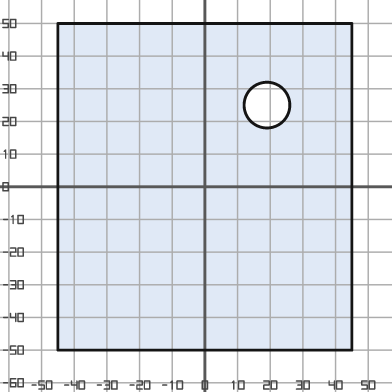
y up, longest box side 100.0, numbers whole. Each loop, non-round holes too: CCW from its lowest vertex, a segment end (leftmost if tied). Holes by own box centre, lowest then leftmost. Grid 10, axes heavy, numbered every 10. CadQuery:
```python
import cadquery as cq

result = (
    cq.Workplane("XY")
    .moveTo(-45.0, -50.0)
    .lineTo(45.0, -50.0)
    .lineTo(45.0, 50.0)
    .lineTo(-45.0, 50.0)
    .close()
    .moveTo(19.0, 25.0)
    .circle(7.0)
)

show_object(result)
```